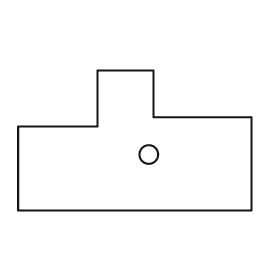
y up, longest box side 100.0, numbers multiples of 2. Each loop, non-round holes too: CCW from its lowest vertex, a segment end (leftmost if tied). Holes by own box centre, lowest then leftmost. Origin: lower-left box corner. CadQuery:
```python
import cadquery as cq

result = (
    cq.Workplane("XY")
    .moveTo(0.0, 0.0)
    .lineTo(100.0, 0.0)
    .lineTo(100.0, 40.0)
    .lineTo(58.0, 40.0)
    .lineTo(58.0, 60.0)
    .lineTo(34.0, 60.0)
    .lineTo(34.0, 36.0)
    .lineTo(0.0, 36.0)
    .close()
    .moveTo(56.0, 24.0)
    .circle(4.0)
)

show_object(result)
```